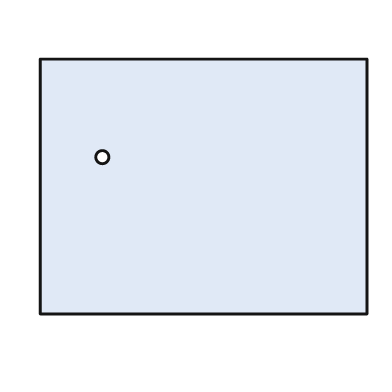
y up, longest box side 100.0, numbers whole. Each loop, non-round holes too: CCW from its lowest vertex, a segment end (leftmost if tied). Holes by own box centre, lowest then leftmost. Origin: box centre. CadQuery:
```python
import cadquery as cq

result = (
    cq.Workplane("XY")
    .moveTo(-50.0, -39.0)
    .lineTo(50.0, -39.0)
    .lineTo(50.0, 39.0)
    .lineTo(-50.0, 39.0)
    .close()
    .moveTo(-31.0, 9.0)
    .circle(2.0)
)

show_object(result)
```